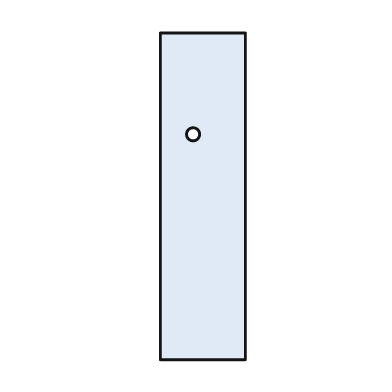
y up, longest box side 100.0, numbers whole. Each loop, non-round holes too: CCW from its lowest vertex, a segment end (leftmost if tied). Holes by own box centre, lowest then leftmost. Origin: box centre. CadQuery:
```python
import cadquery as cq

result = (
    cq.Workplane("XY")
    .moveTo(-13.0, -50.0)
    .lineTo(13.0, -50.0)
    .lineTo(13.0, 50.0)
    .lineTo(-13.0, 50.0)
    .close()
    .moveTo(-3.0, 19.0)
    .circle(2.0)
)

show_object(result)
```